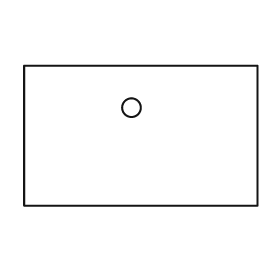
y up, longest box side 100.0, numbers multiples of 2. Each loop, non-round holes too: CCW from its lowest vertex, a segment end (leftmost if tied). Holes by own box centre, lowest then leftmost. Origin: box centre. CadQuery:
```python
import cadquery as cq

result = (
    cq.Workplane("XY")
    .moveTo(-50.0, -30.0)
    .lineTo(50.0, -30.0)
    .lineTo(50.0, 30.0)
    .lineTo(-50.0, 30.0)
    .close()
    .moveTo(-4.0, 12.0)
    .circle(4.0)
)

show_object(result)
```